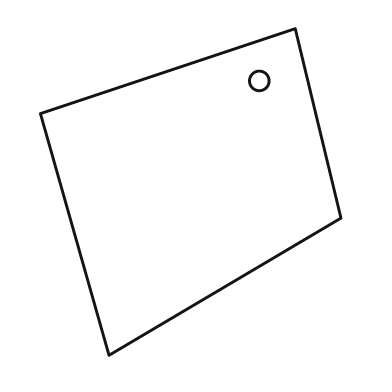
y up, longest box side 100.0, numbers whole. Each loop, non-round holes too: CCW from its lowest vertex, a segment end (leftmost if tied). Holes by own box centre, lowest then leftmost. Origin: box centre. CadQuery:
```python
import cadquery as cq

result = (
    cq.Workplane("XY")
    .moveTo(-25.0, -50.0)
    .lineTo(46.0, -8.0)
    .lineTo(32.0, 50.0)
    .lineTo(-46.0, 24.0)
    .close()
    .moveTo(21.0, 34.0)
    .circle(3.0)
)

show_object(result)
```